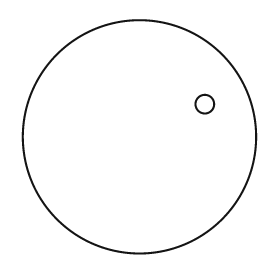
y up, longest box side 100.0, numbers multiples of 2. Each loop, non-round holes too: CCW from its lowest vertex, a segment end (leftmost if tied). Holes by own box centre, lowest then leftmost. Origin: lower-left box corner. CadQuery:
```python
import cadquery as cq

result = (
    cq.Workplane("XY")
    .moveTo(50.0, 50.0)
    .circle(50.0)
    .moveTo(78.0, 64.0)
    .circle(4.0)
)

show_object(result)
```